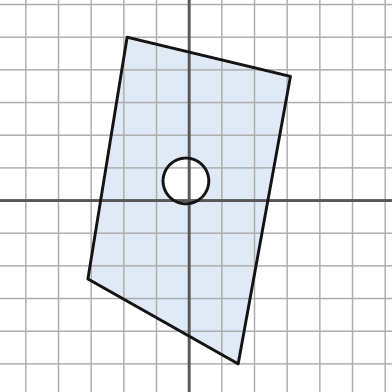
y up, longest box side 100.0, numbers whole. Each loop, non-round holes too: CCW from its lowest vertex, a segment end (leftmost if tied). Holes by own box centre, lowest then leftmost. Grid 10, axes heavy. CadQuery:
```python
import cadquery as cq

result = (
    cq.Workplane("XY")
    .moveTo(15.0, -50.0)
    .lineTo(31.0, 38.0)
    .lineTo(-19.0, 50.0)
    .lineTo(-31.0, -24.0)
    .close()
    .moveTo(-1.0, 6.0)
    .circle(7.0)
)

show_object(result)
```